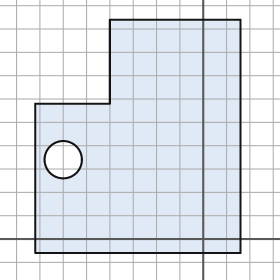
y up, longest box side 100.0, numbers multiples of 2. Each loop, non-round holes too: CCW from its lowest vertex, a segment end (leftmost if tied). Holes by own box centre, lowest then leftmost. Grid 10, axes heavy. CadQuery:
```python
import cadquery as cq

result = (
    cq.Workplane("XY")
    .moveTo(-72.0, -6.0)
    .lineTo(16.0, -6.0)
    .lineTo(16.0, 94.0)
    .lineTo(-40.0, 94.0)
    .lineTo(-40.0, 58.0)
    .lineTo(-72.0, 58.0)
    .close()
    .moveTo(-60.0, 34.0)
    .circle(8.0)
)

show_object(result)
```